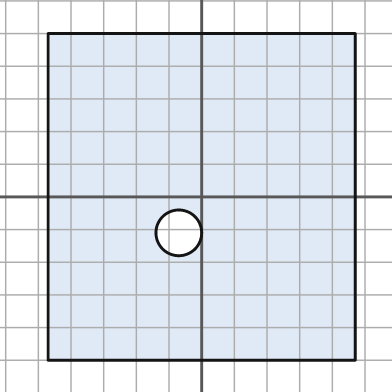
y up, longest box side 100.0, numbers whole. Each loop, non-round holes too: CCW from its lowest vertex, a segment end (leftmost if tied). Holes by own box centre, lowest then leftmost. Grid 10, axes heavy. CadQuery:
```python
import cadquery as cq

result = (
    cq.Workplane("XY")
    .moveTo(-47.0, -50.0)
    .lineTo(47.0, -50.0)
    .lineTo(47.0, 50.0)
    .lineTo(-47.0, 50.0)
    .close()
    .moveTo(-7.0, -11.0)
    .circle(7.0)
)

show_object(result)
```